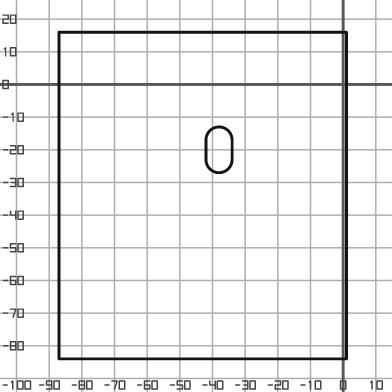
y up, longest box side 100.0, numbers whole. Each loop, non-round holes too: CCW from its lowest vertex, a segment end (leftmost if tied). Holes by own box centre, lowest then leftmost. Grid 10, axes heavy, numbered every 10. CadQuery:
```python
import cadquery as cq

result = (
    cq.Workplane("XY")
    .moveTo(-87.0, -84.0)
    .lineTo(1.0, -84.0)
    .lineTo(1.0, 16.0)
    .lineTo(-87.0, 16.0)
    .close()
    .moveTo(-42.0, -23.0)
    .threePointArc((-38.0, -27.0), (-34.0, -23.0))
    .lineTo(-34.0, -17.0)
    .threePointArc((-38.0, -13.0), (-42.0, -17.0))
    .close()
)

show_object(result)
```